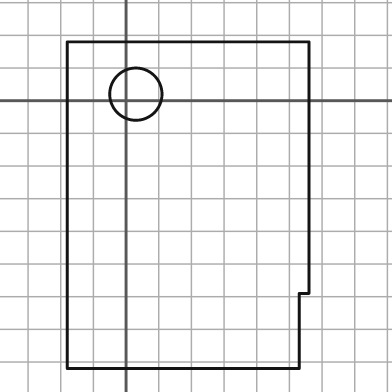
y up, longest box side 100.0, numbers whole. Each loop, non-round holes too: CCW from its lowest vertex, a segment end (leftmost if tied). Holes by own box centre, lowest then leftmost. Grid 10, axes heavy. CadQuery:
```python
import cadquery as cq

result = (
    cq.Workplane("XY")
    .moveTo(-18.0, -82.0)
    .lineTo(53.0, -82.0)
    .lineTo(53.0, -59.0)
    .lineTo(56.0, -59.0)
    .lineTo(56.0, 18.0)
    .lineTo(-18.0, 18.0)
    .close()
    .moveTo(3.0, 2.0)
    .circle(8.0)
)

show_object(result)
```